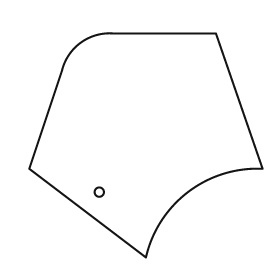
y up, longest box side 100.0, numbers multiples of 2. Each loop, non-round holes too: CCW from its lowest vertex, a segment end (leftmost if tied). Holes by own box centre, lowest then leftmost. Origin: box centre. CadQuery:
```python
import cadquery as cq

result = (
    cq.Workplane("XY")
    .moveTo(0.0, -48.0)
    .threePointArc((18.0, -20.0), (50.0, -10.0))
    .lineTo(30.0, 48.0)
    .lineTo(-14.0, 48.0)
    .threePointArc((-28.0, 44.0), (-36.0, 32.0))
    .lineTo(-50.0, -10.0)
    .close()
    .moveTo(-20.0, -20.0)
    .circle(2.0)
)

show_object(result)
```